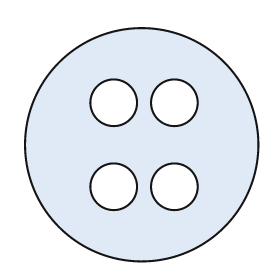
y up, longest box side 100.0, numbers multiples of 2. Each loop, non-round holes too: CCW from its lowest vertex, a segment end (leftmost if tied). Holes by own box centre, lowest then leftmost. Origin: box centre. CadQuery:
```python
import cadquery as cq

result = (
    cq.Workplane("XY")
    .moveTo(0.0, 0.0)
    .circle(50.0)
    .moveTo(-12.0, -18.0)
    .circle(10.0)
    .moveTo(14.0, -18.0)
    .circle(10.0)
    .moveTo(-12.0, 18.0)
    .circle(10.0)
    .moveTo(14.0, 18.0)
    .circle(10.0)
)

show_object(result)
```